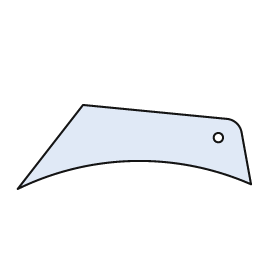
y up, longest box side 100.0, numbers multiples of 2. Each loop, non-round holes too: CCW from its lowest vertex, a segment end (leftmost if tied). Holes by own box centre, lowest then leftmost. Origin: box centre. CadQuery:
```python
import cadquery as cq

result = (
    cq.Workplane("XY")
    .moveTo(-50.0, -18.0)
    .threePointArc((0.0, -6.0), (50.0, -16.0))
    .lineTo(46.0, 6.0)
    .threePointArc((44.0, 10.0), (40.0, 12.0))
    .lineTo(-22.0, 18.0)
    .close()
    .moveTo(36.0, 4.0)
    .circle(2.0)
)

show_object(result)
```